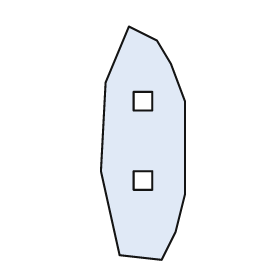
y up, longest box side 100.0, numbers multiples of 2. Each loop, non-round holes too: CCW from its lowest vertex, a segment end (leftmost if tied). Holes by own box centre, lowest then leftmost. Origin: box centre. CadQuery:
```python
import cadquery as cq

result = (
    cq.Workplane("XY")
    .moveTo(8.0, -50.0)
    .lineTo(14.0, -38.0)
    .lineTo(18.0, -22.0)
    .lineTo(18.0, 18.0)
    .lineTo(12.0, 34.0)
    .lineTo(6.0, 44.0)
    .lineTo(-6.0, 50.0)
    .lineTo(-16.0, 26.0)
    .lineTo(-18.0, -12.0)
    .lineTo(-10.0, -48.0)
    .close()
    .moveTo(-4.0, -20.0)
    .lineTo(4.0, -20.0)
    .lineTo(4.0, -12.0)
    .lineTo(-4.0, -12.0)
    .close()
    .moveTo(-4.0, 14.0)
    .lineTo(4.0, 14.0)
    .lineTo(4.0, 22.0)
    .lineTo(-4.0, 22.0)
    .close()
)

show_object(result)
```